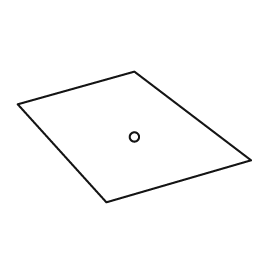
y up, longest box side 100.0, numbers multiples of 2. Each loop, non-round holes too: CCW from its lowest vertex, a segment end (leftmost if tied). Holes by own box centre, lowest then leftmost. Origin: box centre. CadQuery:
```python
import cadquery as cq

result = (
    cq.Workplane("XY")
    .moveTo(-12.0, -28.0)
    .lineTo(50.0, -10.0)
    .lineTo(0.0, 28.0)
    .lineTo(-50.0, 14.0)
    .close()
    .moveTo(0.0, 0.0)
    .circle(2.0)
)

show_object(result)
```